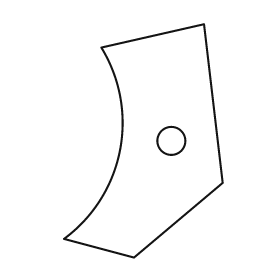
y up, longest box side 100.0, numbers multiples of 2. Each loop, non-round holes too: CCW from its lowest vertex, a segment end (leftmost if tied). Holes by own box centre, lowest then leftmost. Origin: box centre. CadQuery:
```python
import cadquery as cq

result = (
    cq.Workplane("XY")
    .moveTo(-4.0, -50.0)
    .lineTo(34.0, -18.0)
    .lineTo(26.0, 50.0)
    .lineTo(-18.0, 40.0)
    .threePointArc((-10.0, -4.0), (-34.0, -42.0))
    .close()
    .moveTo(12.0, 0.0)
    .circle(6.0)
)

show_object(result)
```